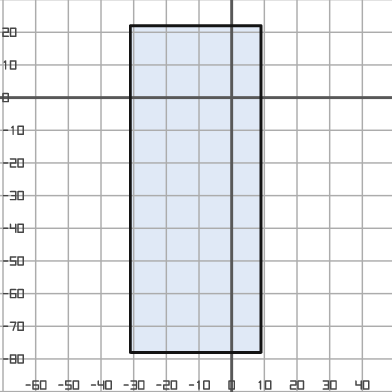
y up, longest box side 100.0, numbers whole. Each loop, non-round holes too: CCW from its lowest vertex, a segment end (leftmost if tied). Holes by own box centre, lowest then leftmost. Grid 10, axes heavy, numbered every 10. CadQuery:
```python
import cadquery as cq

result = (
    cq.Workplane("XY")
    .moveTo(-31.0, -78.0)
    .lineTo(9.0, -78.0)
    .lineTo(9.0, 22.0)
    .lineTo(-31.0, 22.0)
    .close()
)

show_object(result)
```